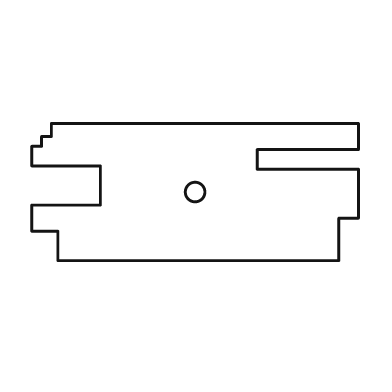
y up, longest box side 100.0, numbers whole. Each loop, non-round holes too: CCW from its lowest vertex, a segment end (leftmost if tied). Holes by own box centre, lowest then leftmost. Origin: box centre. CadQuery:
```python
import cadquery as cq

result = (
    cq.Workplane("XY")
    .moveTo(-42.0, -21.0)
    .lineTo(44.0, -21.0)
    .lineTo(44.0, -8.0)
    .lineTo(50.0, -8.0)
    .lineTo(50.0, 7.0)
    .lineTo(19.0, 7.0)
    .lineTo(19.0, 13.0)
    .lineTo(50.0, 13.0)
    .lineTo(50.0, 21.0)
    .lineTo(-44.0, 21.0)
    .lineTo(-44.0, 17.0)
    .lineTo(-47.0, 17.0)
    .lineTo(-47.0, 14.0)
    .lineTo(-50.0, 14.0)
    .lineTo(-50.0, 8.0)
    .lineTo(-29.0, 8.0)
    .lineTo(-29.0, -4.0)
    .lineTo(-50.0, -4.0)
    .lineTo(-50.0, -12.0)
    .lineTo(-42.0, -12.0)
    .close()
    .moveTo(0.0, 0.0)
    .circle(3.0)
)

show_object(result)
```